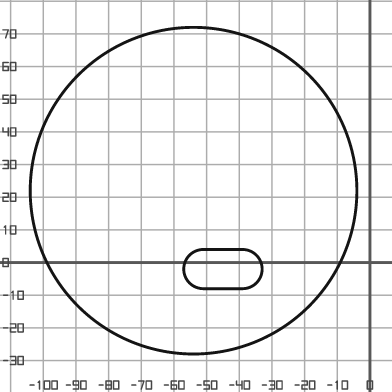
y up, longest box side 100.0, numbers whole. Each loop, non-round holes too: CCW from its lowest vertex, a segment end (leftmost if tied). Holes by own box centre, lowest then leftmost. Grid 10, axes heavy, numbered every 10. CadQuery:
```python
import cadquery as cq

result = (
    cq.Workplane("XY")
    .moveTo(-54.0, 22.0)
    .circle(50.0)
    .moveTo(-51.0, -8.0)
    .lineTo(-39.0, -8.0)
    .threePointArc((-33.0, -2.0), (-39.0, 4.0))
    .lineTo(-51.0, 4.0)
    .threePointArc((-57.0, -2.0), (-51.0, -8.0))
    .close()
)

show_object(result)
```